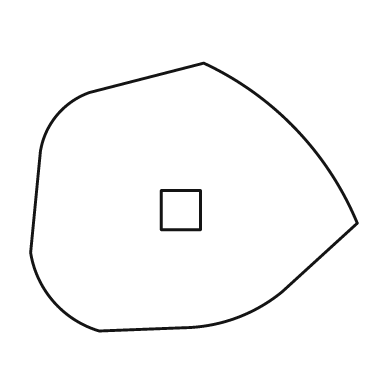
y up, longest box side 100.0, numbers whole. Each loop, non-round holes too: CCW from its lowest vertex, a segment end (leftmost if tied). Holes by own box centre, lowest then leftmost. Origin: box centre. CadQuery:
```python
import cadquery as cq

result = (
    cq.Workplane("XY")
    .moveTo(-29.0, -41.0)
    .lineTo(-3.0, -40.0)
    .threePointArc((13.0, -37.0), (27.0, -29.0))
    .lineTo(50.0, -8.0)
    .threePointArc((31.0, 21.0), (3.0, 41.0))
    .lineTo(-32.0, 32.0)
    .threePointArc((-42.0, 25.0), (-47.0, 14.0))
    .lineTo(-50.0, -17.0)
    .threePointArc((-43.0, -32.0), (-29.0, -41.0))
    .close()
    .moveTo(-10.0, -10.0)
    .lineTo(2.0, -10.0)
    .lineTo(2.0, 2.0)
    .lineTo(-10.0, 2.0)
    .close()
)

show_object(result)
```